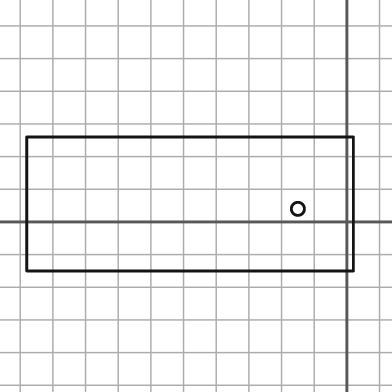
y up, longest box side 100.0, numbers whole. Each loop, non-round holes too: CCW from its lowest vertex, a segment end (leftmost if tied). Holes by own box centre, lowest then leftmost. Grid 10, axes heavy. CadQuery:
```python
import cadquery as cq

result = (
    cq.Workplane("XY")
    .moveTo(-98.0, -15.0)
    .lineTo(2.0, -15.0)
    .lineTo(2.0, 26.0)
    .lineTo(-98.0, 26.0)
    .close()
    .moveTo(-15.0, 4.0)
    .circle(2.0)
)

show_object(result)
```